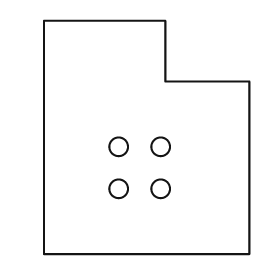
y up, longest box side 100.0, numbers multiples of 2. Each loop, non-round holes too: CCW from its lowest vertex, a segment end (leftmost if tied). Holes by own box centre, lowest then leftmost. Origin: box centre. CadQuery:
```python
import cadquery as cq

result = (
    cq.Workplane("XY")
    .moveTo(-44.0, -50.0)
    .lineTo(44.0, -50.0)
    .lineTo(44.0, 24.0)
    .lineTo(8.0, 24.0)
    .lineTo(8.0, 50.0)
    .lineTo(-44.0, 50.0)
    .close()
    .moveTo(-12.0, -22.0)
    .circle(4.0)
    .moveTo(6.0, -22.0)
    .circle(4.0)
    .moveTo(-12.0, -4.0)
    .circle(4.0)
    .moveTo(6.0, -4.0)
    .circle(4.0)
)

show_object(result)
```